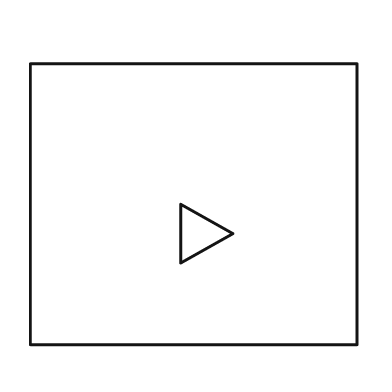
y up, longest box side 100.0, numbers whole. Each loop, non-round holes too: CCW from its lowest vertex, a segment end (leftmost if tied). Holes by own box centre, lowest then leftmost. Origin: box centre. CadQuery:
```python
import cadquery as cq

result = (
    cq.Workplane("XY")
    .moveTo(-50.0, -43.0)
    .lineTo(50.0, -43.0)
    .lineTo(50.0, 43.0)
    .lineTo(-50.0, 43.0)
    .close()
    .moveTo(-4.0, -18.0)
    .lineTo(12.0, -9.0)
    .lineTo(-4.0, 0.0)
    .close()
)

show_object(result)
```